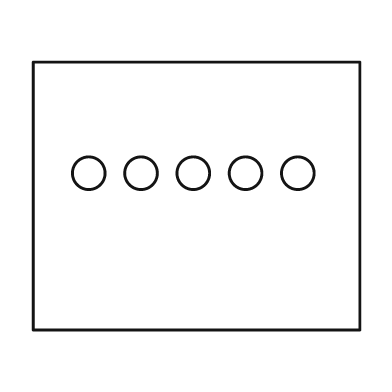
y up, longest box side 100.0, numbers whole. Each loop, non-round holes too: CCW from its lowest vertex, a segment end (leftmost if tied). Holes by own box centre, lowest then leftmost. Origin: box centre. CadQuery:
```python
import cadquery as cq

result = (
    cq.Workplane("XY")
    .moveTo(-50.0, -41.0)
    .lineTo(50.0, -41.0)
    .lineTo(50.0, 41.0)
    .lineTo(-50.0, 41.0)
    .close()
    .moveTo(-33.0, 7.0)
    .circle(5.0)
    .moveTo(-17.0, 7.0)
    .circle(5.0)
    .moveTo(-1.0, 7.0)
    .circle(5.0)
    .moveTo(15.0, 7.0)
    .circle(5.0)
    .moveTo(31.0, 7.0)
    .circle(5.0)
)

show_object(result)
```